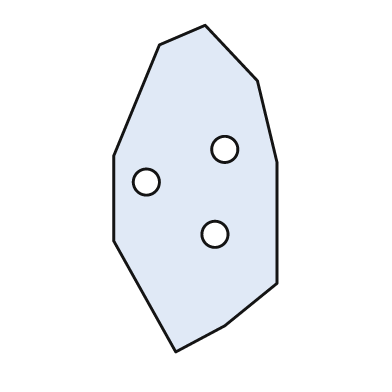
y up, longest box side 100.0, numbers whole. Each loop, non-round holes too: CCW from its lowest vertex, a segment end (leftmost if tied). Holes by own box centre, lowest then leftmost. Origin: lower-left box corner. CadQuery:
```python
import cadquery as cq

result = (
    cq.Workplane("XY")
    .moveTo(19.0, 0.0)
    .lineTo(34.0, 8.0)
    .lineTo(50.0, 21.0)
    .lineTo(50.0, 58.0)
    .lineTo(44.0, 83.0)
    .lineTo(28.0, 100.0)
    .lineTo(14.0, 94.0)
    .lineTo(0.0, 60.0)
    .lineTo(0.0, 34.0)
    .close()
    .moveTo(31.0, 36.0)
    .circle(4.0)
    .moveTo(10.0, 52.0)
    .circle(4.0)
    .moveTo(34.0, 62.0)
    .circle(4.0)
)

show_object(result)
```